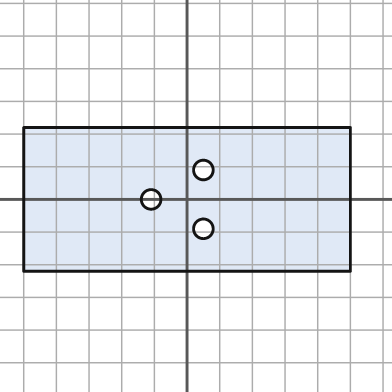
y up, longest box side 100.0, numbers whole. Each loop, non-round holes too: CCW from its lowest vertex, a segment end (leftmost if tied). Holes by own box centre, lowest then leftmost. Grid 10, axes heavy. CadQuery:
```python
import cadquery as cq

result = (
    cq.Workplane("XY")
    .moveTo(-50.0, -22.0)
    .lineTo(50.0, -22.0)
    .lineTo(50.0, 22.0)
    .lineTo(-50.0, 22.0)
    .close()
    .moveTo(5.0, -9.0)
    .circle(3.0)
    .moveTo(-11.0, 0.0)
    .circle(3.0)
    .moveTo(5.0, 9.0)
    .circle(3.0)
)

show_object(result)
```